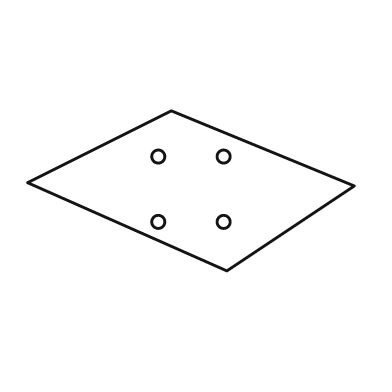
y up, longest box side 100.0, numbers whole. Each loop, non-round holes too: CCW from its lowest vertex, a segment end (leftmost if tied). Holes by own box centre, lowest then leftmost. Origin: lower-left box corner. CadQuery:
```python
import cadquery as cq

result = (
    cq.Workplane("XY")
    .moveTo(61.0, 0.0)
    .lineTo(100.0, 26.0)
    .lineTo(44.0, 49.0)
    .lineTo(0.0, 27.0)
    .close()
    .moveTo(40.0, 15.0)
    .circle(2.0)
    .moveTo(60.0, 15.0)
    .circle(2.0)
    .moveTo(40.0, 35.0)
    .circle(2.0)
    .moveTo(60.0, 35.0)
    .circle(2.0)
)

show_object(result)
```